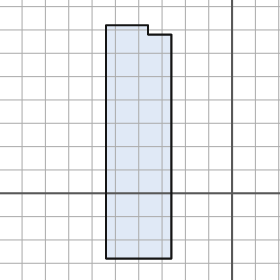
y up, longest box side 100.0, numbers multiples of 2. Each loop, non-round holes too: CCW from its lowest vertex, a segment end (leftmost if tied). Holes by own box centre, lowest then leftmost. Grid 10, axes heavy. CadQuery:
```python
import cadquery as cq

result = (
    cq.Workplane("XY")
    .moveTo(-54.0, -28.0)
    .lineTo(-26.0, -28.0)
    .lineTo(-26.0, 68.0)
    .lineTo(-36.0, 68.0)
    .lineTo(-36.0, 72.0)
    .lineTo(-54.0, 72.0)
    .close()
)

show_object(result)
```